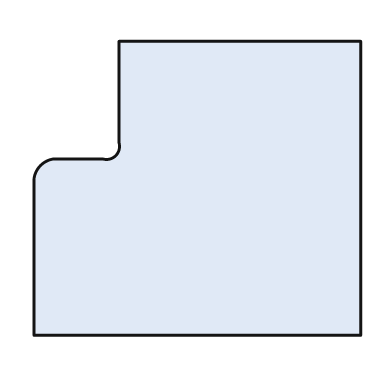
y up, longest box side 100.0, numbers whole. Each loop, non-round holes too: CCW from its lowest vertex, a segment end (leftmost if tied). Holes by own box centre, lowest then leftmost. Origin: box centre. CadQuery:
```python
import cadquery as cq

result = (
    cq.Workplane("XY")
    .moveTo(-50.0, -45.0)
    .lineTo(50.0, -45.0)
    .lineTo(50.0, 45.0)
    .lineTo(-24.0, 45.0)
    .lineTo(-24.0, 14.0)
    .threePointArc((-25.0, 10.0), (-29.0, 9.0))
    .lineTo(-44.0, 9.0)
    .threePointArc((-48.0, 7.0), (-50.0, 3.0))
    .close()
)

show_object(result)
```